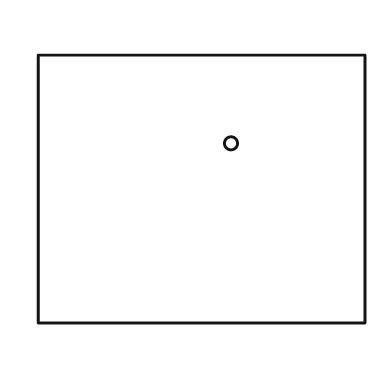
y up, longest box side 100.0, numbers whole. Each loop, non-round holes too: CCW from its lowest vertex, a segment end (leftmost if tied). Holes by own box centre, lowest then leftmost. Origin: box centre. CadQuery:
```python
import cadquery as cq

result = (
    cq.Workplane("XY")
    .moveTo(-50.0, -41.0)
    .lineTo(50.0, -41.0)
    .lineTo(50.0, 41.0)
    .lineTo(-50.0, 41.0)
    .close()
    .moveTo(9.0, 14.0)
    .circle(2.0)
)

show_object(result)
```